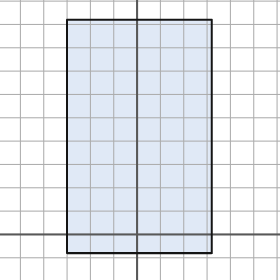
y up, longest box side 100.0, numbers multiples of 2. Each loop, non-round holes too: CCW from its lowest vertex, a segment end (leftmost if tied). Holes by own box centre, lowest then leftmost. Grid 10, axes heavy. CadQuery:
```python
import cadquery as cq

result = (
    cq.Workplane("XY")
    .moveTo(-30.0, -8.0)
    .lineTo(32.0, -8.0)
    .lineTo(32.0, 92.0)
    .lineTo(-30.0, 92.0)
    .close()
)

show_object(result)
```